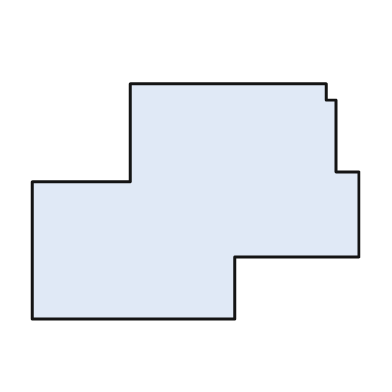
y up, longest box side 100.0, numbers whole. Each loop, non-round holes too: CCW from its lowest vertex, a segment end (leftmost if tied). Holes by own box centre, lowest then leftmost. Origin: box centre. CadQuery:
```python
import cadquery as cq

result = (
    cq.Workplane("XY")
    .moveTo(-50.0, -36.0)
    .lineTo(12.0, -36.0)
    .lineTo(12.0, -17.0)
    .lineTo(50.0, -17.0)
    .lineTo(50.0, 9.0)
    .lineTo(43.0, 9.0)
    .lineTo(43.0, 31.0)
    .lineTo(40.0, 31.0)
    .lineTo(40.0, 36.0)
    .lineTo(-20.0, 36.0)
    .lineTo(-20.0, 6.0)
    .lineTo(-50.0, 6.0)
    .close()
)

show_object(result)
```